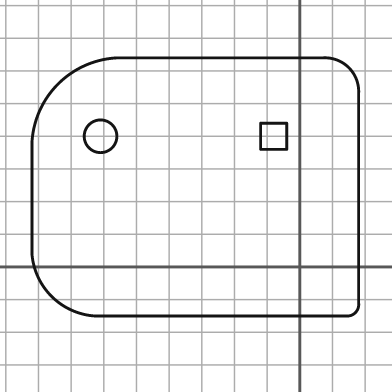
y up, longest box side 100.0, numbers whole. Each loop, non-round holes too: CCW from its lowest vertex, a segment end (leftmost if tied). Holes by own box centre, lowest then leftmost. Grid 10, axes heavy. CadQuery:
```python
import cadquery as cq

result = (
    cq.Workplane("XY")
    .moveTo(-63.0, -15.0)
    .lineTo(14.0, -15.0)
    .threePointArc((17.0, -14.0), (18.0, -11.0))
    .lineTo(18.0, 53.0)
    .threePointArc((15.0, 61.0), (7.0, 64.0))
    .lineTo(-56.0, 64.0)
    .threePointArc((-74.0, 56.0), (-82.0, 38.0))
    .lineTo(-82.0, 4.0)
    .threePointArc((-76.0, -9.0), (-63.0, -15.0))
    .close()
    .moveTo(-61.0, 40.0)
    .circle(5.0)
    .moveTo(-12.0, 36.0)
    .lineTo(-4.0, 36.0)
    .lineTo(-4.0, 44.0)
    .lineTo(-12.0, 44.0)
    .close()
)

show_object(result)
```